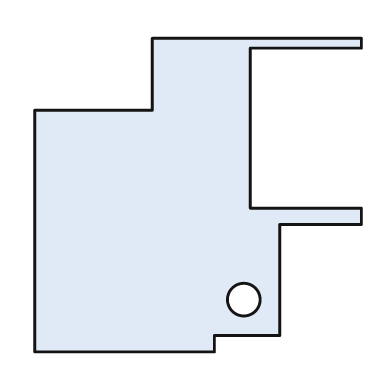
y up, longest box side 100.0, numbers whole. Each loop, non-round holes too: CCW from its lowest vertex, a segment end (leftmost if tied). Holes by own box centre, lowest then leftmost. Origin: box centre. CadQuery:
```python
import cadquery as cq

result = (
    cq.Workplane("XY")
    .moveTo(-50.0, -48.0)
    .lineTo(5.0, -48.0)
    .lineTo(5.0, -43.0)
    .lineTo(25.0, -43.0)
    .lineTo(25.0, -9.0)
    .lineTo(50.0, -9.0)
    .lineTo(50.0, -4.0)
    .lineTo(16.0, -4.0)
    .lineTo(16.0, 45.0)
    .lineTo(50.0, 45.0)
    .lineTo(50.0, 48.0)
    .lineTo(-14.0, 48.0)
    .lineTo(-14.0, 26.0)
    .lineTo(-50.0, 26.0)
    .close()
    .moveTo(14.0, -32.0)
    .circle(5.0)
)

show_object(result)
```